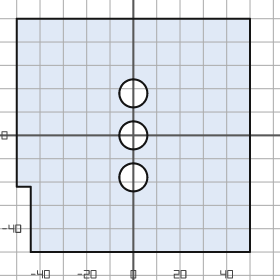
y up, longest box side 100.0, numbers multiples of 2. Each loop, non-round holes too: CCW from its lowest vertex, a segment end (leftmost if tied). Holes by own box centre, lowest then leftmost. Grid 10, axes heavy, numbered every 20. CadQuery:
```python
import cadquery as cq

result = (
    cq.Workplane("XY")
    .moveTo(-44.0, -50.0)
    .lineTo(50.0, -50.0)
    .lineTo(50.0, 50.0)
    .lineTo(-50.0, 50.0)
    .lineTo(-50.0, -22.0)
    .lineTo(-44.0, -22.0)
    .close()
    .moveTo(0.0, -18.0)
    .circle(6.0)
    .moveTo(0.0, 0.0)
    .circle(6.0)
    .moveTo(0.0, 18.0)
    .circle(6.0)
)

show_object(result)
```